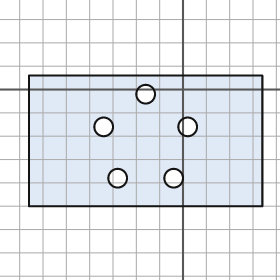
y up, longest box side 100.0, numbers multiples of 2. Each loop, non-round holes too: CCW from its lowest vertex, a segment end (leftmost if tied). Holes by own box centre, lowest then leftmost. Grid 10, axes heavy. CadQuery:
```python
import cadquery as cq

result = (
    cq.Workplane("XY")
    .moveTo(-66.0, -50.0)
    .lineTo(34.0, -50.0)
    .lineTo(34.0, 6.0)
    .lineTo(-66.0, 6.0)
    .close()
    .moveTo(-28.0, -38.0)
    .circle(4.0)
    .moveTo(-4.0, -38.0)
    .circle(4.0)
    .moveTo(-34.0, -16.0)
    .circle(4.0)
    .moveTo(2.0, -16.0)
    .circle(4.0)
    .moveTo(-16.0, -2.0)
    .circle(4.0)
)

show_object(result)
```